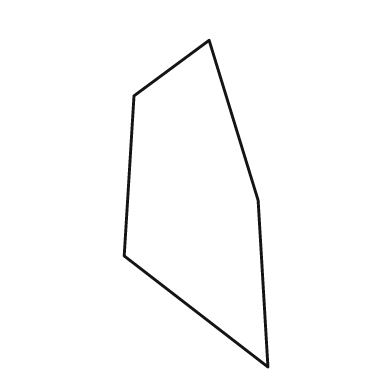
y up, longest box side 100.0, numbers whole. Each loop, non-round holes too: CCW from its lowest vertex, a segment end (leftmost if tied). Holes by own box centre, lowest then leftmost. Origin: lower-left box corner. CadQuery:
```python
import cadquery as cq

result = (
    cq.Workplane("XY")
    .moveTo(44.0, 0.0)
    .lineTo(41.0, 51.0)
    .lineTo(26.0, 100.0)
    .lineTo(3.0, 83.0)
    .lineTo(0.0, 34.0)
    .close()
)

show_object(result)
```